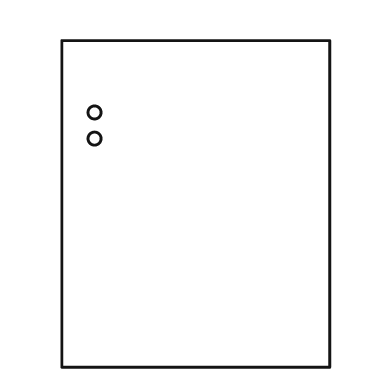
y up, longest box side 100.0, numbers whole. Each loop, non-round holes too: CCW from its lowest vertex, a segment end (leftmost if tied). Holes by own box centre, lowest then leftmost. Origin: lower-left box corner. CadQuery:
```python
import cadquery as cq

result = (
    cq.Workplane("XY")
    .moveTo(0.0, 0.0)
    .lineTo(82.0, 0.0)
    .lineTo(82.0, 100.0)
    .lineTo(0.0, 100.0)
    .close()
    .moveTo(10.0, 70.0)
    .circle(2.0)
    .moveTo(10.0, 78.0)
    .circle(2.0)
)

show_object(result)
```